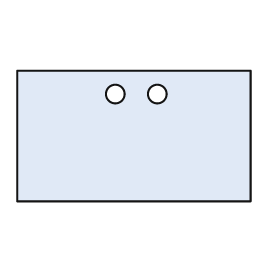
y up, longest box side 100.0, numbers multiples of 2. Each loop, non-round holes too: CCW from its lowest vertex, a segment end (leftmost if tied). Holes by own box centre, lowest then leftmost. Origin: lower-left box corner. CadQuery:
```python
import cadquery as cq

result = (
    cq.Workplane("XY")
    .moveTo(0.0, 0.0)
    .lineTo(100.0, 0.0)
    .lineTo(100.0, 56.0)
    .lineTo(0.0, 56.0)
    .close()
    .moveTo(42.0, 46.0)
    .circle(4.0)
    .moveTo(60.0, 46.0)
    .circle(4.0)
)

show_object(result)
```